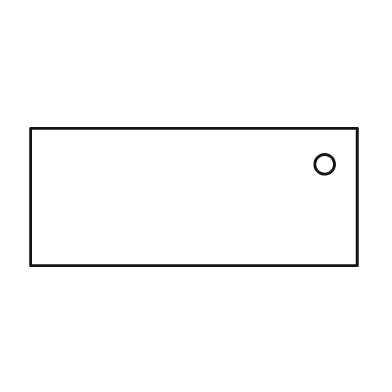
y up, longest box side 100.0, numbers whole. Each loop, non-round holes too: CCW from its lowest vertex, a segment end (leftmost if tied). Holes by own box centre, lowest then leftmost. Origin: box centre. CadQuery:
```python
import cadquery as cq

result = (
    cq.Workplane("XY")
    .moveTo(-50.0, -21.0)
    .lineTo(50.0, -21.0)
    .lineTo(50.0, 21.0)
    .lineTo(-50.0, 21.0)
    .close()
    .moveTo(40.0, 10.0)
    .circle(3.0)
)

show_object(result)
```